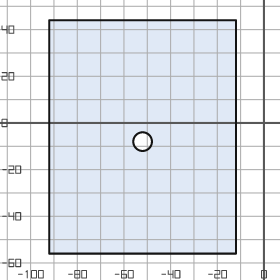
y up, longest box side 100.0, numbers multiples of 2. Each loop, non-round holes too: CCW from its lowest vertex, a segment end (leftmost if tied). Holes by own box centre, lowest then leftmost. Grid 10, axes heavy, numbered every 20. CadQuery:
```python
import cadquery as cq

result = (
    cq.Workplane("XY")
    .moveTo(-92.0, -56.0)
    .lineTo(-12.0, -56.0)
    .lineTo(-12.0, 44.0)
    .lineTo(-92.0, 44.0)
    .close()
    .moveTo(-52.0, -8.0)
    .circle(4.0)
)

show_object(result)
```